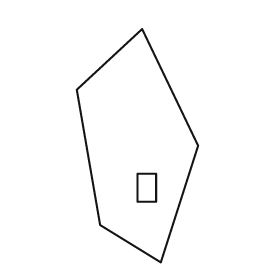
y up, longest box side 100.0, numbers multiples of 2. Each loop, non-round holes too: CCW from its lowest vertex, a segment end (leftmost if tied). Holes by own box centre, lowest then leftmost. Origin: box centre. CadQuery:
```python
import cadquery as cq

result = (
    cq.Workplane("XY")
    .moveTo(10.0, -50.0)
    .lineTo(26.0, 0.0)
    .lineTo(2.0, 50.0)
    .lineTo(-26.0, 24.0)
    .lineTo(-16.0, -34.0)
    .close()
    .moveTo(0.0, -24.0)
    .lineTo(8.0, -24.0)
    .lineTo(8.0, -12.0)
    .lineTo(0.0, -12.0)
    .close()
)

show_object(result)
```